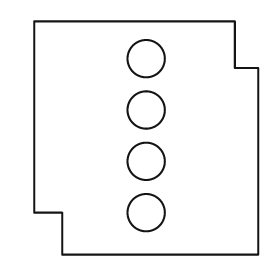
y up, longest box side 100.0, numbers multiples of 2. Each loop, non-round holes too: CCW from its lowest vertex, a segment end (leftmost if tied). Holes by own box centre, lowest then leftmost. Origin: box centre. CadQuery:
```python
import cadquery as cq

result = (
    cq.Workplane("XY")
    .moveTo(-36.0, -50.0)
    .lineTo(48.0, -50.0)
    .lineTo(48.0, 30.0)
    .lineTo(38.0, 30.0)
    .lineTo(38.0, 50.0)
    .lineTo(-48.0, 50.0)
    .lineTo(-48.0, -32.0)
    .lineTo(-36.0, -32.0)
    .close()
    .moveTo(0.0, -32.0)
    .circle(8.0)
    .moveTo(0.0, -10.0)
    .circle(8.0)
    .moveTo(0.0, 12.0)
    .circle(8.0)
    .moveTo(0.0, 34.0)
    .circle(8.0)
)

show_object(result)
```